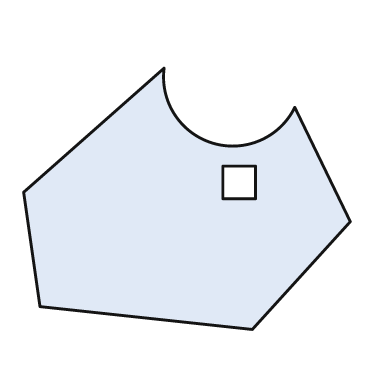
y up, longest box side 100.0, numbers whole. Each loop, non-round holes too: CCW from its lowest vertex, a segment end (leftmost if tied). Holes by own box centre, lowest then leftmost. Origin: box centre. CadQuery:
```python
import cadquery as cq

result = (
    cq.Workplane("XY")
    .moveTo(20.0, -40.0)
    .lineTo(50.0, -7.0)
    .lineTo(33.0, 28.0)
    .threePointArc((8.0, 17.0), (-7.0, 40.0))
    .lineTo(-50.0, 2.0)
    .lineTo(-45.0, -33.0)
    .close()
    .moveTo(11.0, 0.0)
    .lineTo(21.0, 0.0)
    .lineTo(21.0, 10.0)
    .lineTo(11.0, 10.0)
    .close()
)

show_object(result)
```